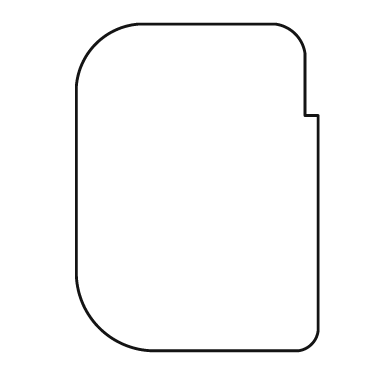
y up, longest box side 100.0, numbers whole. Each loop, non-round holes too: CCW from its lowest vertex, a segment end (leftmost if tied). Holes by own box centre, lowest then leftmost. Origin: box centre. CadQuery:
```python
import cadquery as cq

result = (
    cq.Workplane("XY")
    .moveTo(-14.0, -50.0)
    .lineTo(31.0, -50.0)
    .threePointArc((35.0, -48.0), (37.0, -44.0))
    .lineTo(37.0, 22.0)
    .lineTo(33.0, 22.0)
    .lineTo(33.0, 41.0)
    .threePointArc((30.0, 47.0), (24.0, 50.0))
    .lineTo(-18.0, 50.0)
    .threePointArc((-31.0, 44.0), (-37.0, 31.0))
    .lineTo(-37.0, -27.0)
    .threePointArc((-30.0, -43.0), (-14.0, -50.0))
    .close()
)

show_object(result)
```